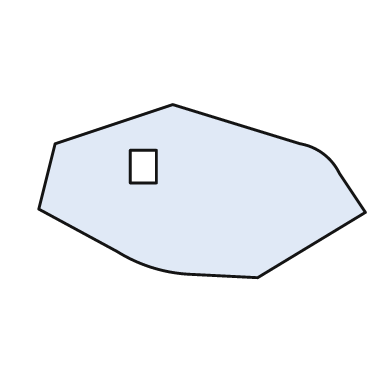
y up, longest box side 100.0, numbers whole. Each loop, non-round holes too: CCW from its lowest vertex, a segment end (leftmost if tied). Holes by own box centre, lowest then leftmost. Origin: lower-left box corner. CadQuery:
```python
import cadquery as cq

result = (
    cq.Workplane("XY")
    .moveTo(67.0, 0.0)
    .lineTo(100.0, 20.0)
    .lineTo(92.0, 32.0)
    .threePointArc((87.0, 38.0), (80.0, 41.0))
    .lineTo(41.0, 53.0)
    .lineTo(5.0, 41.0)
    .lineTo(0.0, 21.0)
    .lineTo(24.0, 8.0)
    .threePointArc((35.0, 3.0), (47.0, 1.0))
    .close()
    .moveTo(28.0, 29.0)
    .lineTo(36.0, 29.0)
    .lineTo(36.0, 39.0)
    .lineTo(28.0, 39.0)
    .close()
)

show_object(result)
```